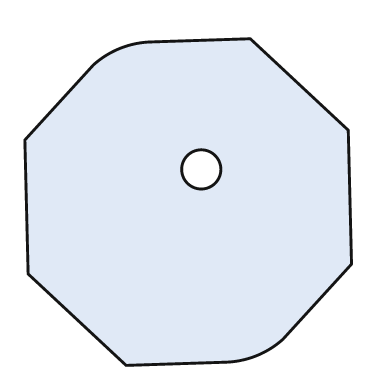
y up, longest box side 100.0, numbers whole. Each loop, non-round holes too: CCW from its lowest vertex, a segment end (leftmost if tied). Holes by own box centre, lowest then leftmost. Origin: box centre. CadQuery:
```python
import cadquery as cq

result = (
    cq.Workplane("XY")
    .moveTo(-19.0, -50.0)
    .lineTo(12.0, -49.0)
    .threePointArc((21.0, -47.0), (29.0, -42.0))
    .lineTo(50.0, -19.0)
    .lineTo(49.0, 22.0)
    .lineTo(19.0, 50.0)
    .lineTo(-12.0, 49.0)
    .threePointArc((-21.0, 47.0), (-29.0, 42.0))
    .lineTo(-50.0, 19.0)
    .lineTo(-49.0, -22.0)
    .close()
    .moveTo(4.0, 10.0)
    .circle(6.0)
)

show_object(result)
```